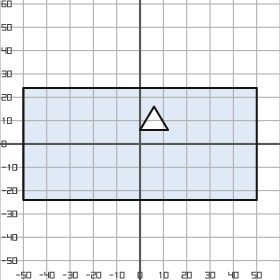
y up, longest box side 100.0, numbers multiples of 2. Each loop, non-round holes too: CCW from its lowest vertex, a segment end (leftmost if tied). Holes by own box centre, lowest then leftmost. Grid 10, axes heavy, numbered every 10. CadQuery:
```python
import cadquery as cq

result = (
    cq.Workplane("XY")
    .moveTo(-50.0, -24.0)
    .lineTo(50.0, -24.0)
    .lineTo(50.0, 24.0)
    .lineTo(-50.0, 24.0)
    .close()
    .moveTo(0.0, 6.0)
    .lineTo(12.0, 6.0)
    .lineTo(6.0, 16.0)
    .close()
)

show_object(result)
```